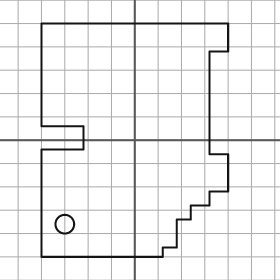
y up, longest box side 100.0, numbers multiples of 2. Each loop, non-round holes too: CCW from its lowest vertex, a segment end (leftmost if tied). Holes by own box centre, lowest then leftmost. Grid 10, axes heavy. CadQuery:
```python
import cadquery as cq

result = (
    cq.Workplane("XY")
    .moveTo(-40.0, -50.0)
    .lineTo(12.0, -50.0)
    .lineTo(12.0, -46.0)
    .lineTo(18.0, -46.0)
    .lineTo(18.0, -34.0)
    .lineTo(24.0, -34.0)
    .lineTo(24.0, -28.0)
    .lineTo(32.0, -28.0)
    .lineTo(32.0, -22.0)
    .lineTo(40.0, -22.0)
    .lineTo(40.0, -6.0)
    .lineTo(32.0, -6.0)
    .lineTo(32.0, 38.0)
    .lineTo(40.0, 38.0)
    .lineTo(40.0, 50.0)
    .lineTo(-40.0, 50.0)
    .lineTo(-40.0, 6.0)
    .lineTo(-22.0, 6.0)
    .lineTo(-22.0, -4.0)
    .lineTo(-40.0, -4.0)
    .close()
    .moveTo(-30.0, -36.0)
    .circle(4.0)
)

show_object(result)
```